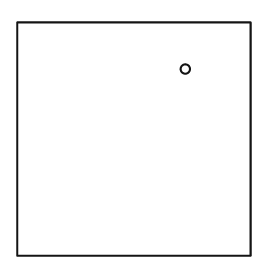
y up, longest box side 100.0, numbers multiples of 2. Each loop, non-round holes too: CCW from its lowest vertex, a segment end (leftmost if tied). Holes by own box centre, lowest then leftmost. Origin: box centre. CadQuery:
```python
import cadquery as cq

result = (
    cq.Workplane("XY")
    .moveTo(-50.0, -50.0)
    .lineTo(50.0, -50.0)
    .lineTo(50.0, 50.0)
    .lineTo(-50.0, 50.0)
    .close()
    .moveTo(22.0, 30.0)
    .circle(2.0)
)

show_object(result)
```